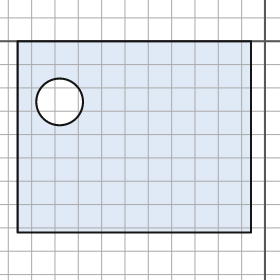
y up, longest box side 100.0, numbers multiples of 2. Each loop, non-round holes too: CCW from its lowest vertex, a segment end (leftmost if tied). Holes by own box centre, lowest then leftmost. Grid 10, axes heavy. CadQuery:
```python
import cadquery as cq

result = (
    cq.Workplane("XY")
    .moveTo(-106.0, -82.0)
    .lineTo(-6.0, -82.0)
    .lineTo(-6.0, 0.0)
    .lineTo(-106.0, 0.0)
    .close()
    .moveTo(-88.0, -26.0)
    .circle(10.0)
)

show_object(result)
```